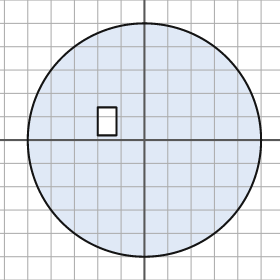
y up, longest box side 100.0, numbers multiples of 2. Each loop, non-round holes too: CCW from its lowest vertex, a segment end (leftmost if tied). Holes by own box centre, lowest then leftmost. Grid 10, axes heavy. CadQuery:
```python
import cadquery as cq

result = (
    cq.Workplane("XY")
    .moveTo(0.0, 0.0)
    .circle(50.0)
    .moveTo(-20.0, 2.0)
    .lineTo(-12.0, 2.0)
    .lineTo(-12.0, 14.0)
    .lineTo(-20.0, 14.0)
    .close()
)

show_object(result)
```